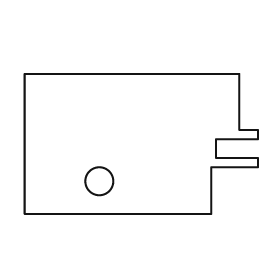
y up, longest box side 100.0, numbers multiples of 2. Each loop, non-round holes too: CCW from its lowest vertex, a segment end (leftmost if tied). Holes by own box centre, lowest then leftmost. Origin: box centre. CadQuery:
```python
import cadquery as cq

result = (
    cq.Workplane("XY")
    .moveTo(-50.0, -30.0)
    .lineTo(30.0, -30.0)
    .lineTo(30.0, -10.0)
    .lineTo(50.0, -10.0)
    .lineTo(50.0, -6.0)
    .lineTo(32.0, -6.0)
    .lineTo(32.0, 2.0)
    .lineTo(50.0, 2.0)
    .lineTo(50.0, 6.0)
    .lineTo(42.0, 6.0)
    .lineTo(42.0, 30.0)
    .lineTo(-50.0, 30.0)
    .close()
    .moveTo(-18.0, -16.0)
    .circle(6.0)
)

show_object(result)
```